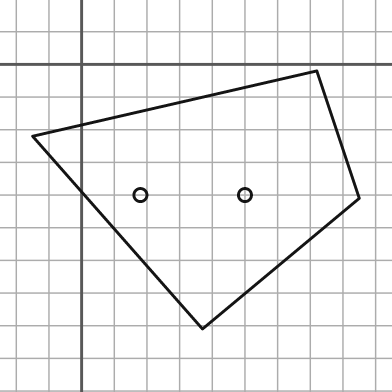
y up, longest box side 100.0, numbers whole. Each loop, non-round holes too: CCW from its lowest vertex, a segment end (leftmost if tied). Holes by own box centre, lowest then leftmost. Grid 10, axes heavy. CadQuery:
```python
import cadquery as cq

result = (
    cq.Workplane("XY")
    .moveTo(37.0, -81.0)
    .lineTo(85.0, -41.0)
    .lineTo(72.0, -2.0)
    .lineTo(-15.0, -22.0)
    .close()
    .moveTo(18.0, -40.0)
    .circle(2.0)
    .moveTo(50.0, -40.0)
    .circle(2.0)
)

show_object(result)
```